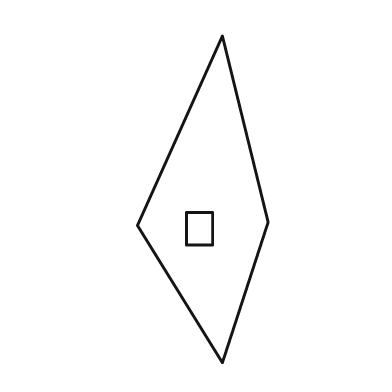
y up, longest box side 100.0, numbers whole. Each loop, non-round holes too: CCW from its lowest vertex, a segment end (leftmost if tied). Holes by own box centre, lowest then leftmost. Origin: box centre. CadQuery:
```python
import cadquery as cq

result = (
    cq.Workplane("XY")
    .moveTo(6.0, -50.0)
    .lineTo(20.0, -7.0)
    .lineTo(6.0, 50.0)
    .lineTo(-20.0, -8.0)
    .close()
    .moveTo(-5.0, -14.0)
    .lineTo(3.0, -14.0)
    .lineTo(3.0, -4.0)
    .lineTo(-5.0, -4.0)
    .close()
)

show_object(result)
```